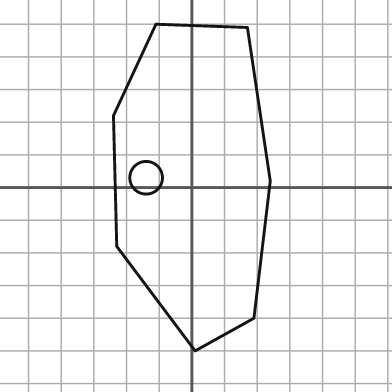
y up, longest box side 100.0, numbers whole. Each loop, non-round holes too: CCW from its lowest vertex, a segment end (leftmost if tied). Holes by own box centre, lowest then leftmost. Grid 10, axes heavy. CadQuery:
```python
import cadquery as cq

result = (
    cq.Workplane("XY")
    .moveTo(1.0, -50.0)
    .lineTo(19.0, -40.0)
    .lineTo(24.0, 2.0)
    .lineTo(17.0, 49.0)
    .lineTo(-11.0, 50.0)
    .lineTo(-24.0, 22.0)
    .lineTo(-23.0, -18.0)
    .close()
    .moveTo(-14.0, 3.0)
    .circle(5.0)
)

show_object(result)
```